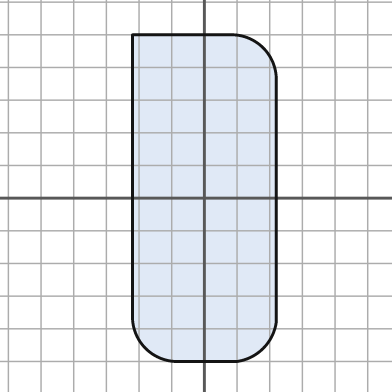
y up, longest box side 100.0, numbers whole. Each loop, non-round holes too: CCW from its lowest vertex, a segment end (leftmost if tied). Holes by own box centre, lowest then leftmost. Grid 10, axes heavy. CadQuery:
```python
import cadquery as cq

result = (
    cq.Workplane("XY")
    .moveTo(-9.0, -50.0)
    .lineTo(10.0, -50.0)
    .threePointArc((18.0, -46.0), (22.0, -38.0))
    .lineTo(22.0, 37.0)
    .threePointArc((18.0, 46.0), (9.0, 50.0))
    .lineTo(-22.0, 50.0)
    .lineTo(-22.0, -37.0)
    .threePointArc((-18.0, -46.0), (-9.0, -50.0))
    .close()
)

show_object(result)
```